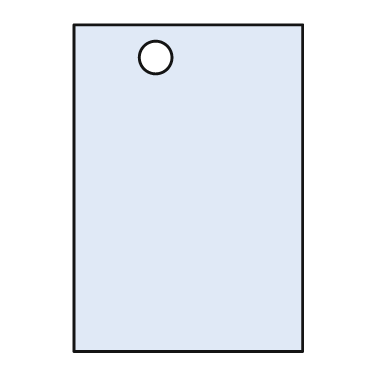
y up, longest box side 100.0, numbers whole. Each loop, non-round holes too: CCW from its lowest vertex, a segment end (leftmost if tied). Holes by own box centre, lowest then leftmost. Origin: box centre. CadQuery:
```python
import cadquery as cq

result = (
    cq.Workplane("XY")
    .moveTo(-35.0, -50.0)
    .lineTo(35.0, -50.0)
    .lineTo(35.0, 50.0)
    .lineTo(-35.0, 50.0)
    .close()
    .moveTo(-10.0, 40.0)
    .circle(5.0)
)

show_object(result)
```